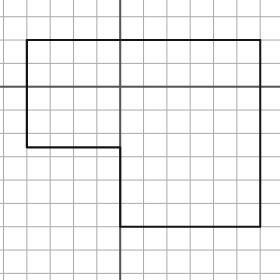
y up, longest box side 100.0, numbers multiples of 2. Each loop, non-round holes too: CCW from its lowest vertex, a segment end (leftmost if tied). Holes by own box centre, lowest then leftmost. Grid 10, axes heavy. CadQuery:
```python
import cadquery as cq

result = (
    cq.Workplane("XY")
    .moveTo(0.0, -60.0)
    .lineTo(60.0, -60.0)
    .lineTo(60.0, 20.0)
    .lineTo(-40.0, 20.0)
    .lineTo(-40.0, -26.0)
    .lineTo(0.0, -26.0)
    .close()
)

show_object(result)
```